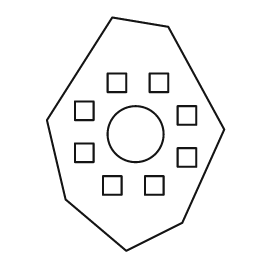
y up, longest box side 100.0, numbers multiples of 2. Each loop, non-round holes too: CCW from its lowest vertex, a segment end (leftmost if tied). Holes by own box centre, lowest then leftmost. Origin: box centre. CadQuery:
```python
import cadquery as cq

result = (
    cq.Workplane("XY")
    .moveTo(-4.0, -50.0)
    .lineTo(20.0, -38.0)
    .lineTo(38.0, 2.0)
    .lineTo(14.0, 46.0)
    .lineTo(-10.0, 50.0)
    .lineTo(-38.0, 6.0)
    .lineTo(-30.0, -28.0)
    .close()
    .moveTo(-14.0, -26.0)
    .lineTo(-6.0, -26.0)
    .lineTo(-6.0, -18.0)
    .lineTo(-14.0, -18.0)
    .close()
    .moveTo(4.0, -26.0)
    .lineTo(12.0, -26.0)
    .lineTo(12.0, -18.0)
    .lineTo(4.0, -18.0)
    .close()
    .moveTo(18.0, -14.0)
    .lineTo(26.0, -14.0)
    .lineTo(26.0, -6.0)
    .lineTo(18.0, -6.0)
    .close()
    .moveTo(-26.0, -12.0)
    .lineTo(-18.0, -12.0)
    .lineTo(-18.0, -4.0)
    .lineTo(-26.0, -4.0)
    .close()
    .moveTo(0.0, 0.0)
    .circle(12.0)
    .moveTo(18.0, 4.0)
    .lineTo(26.0, 4.0)
    .lineTo(26.0, 12.0)
    .lineTo(18.0, 12.0)
    .close()
    .moveTo(-26.0, 6.0)
    .lineTo(-18.0, 6.0)
    .lineTo(-18.0, 14.0)
    .lineTo(-26.0, 14.0)
    .close()
    .moveTo(-12.0, 18.0)
    .lineTo(-4.0, 18.0)
    .lineTo(-4.0, 26.0)
    .lineTo(-12.0, 26.0)
    .close()
    .moveTo(6.0, 18.0)
    .lineTo(14.0, 18.0)
    .lineTo(14.0, 26.0)
    .lineTo(6.0, 26.0)
    .close()
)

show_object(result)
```